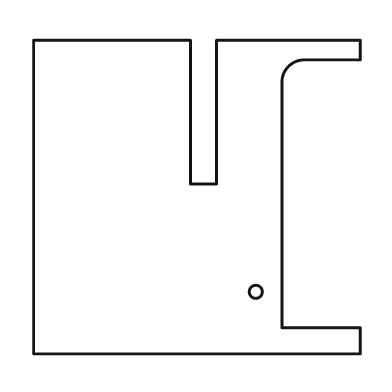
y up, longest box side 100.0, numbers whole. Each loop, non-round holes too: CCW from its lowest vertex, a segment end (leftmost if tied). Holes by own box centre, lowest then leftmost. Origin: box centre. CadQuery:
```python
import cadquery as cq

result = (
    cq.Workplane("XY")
    .moveTo(-50.0, -48.0)
    .lineTo(50.0, -48.0)
    .lineTo(50.0, -40.0)
    .lineTo(26.0, -40.0)
    .lineTo(26.0, 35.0)
    .threePointArc((28.0, 40.0), (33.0, 42.0))
    .lineTo(50.0, 42.0)
    .lineTo(50.0, 48.0)
    .lineTo(6.0, 48.0)
    .lineTo(6.0, 4.0)
    .lineTo(-2.0, 4.0)
    .lineTo(-2.0, 48.0)
    .lineTo(-50.0, 48.0)
    .close()
    .moveTo(18.0, -29.0)
    .circle(2.0)
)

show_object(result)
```